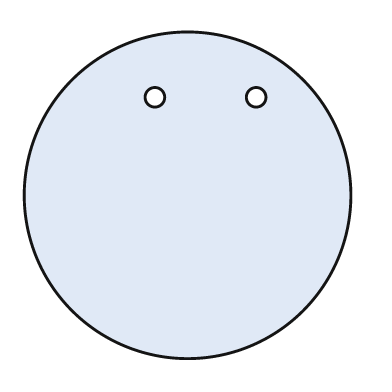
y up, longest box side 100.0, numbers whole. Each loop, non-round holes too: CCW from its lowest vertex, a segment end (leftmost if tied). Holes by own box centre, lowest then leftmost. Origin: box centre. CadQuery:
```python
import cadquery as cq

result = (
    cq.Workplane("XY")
    .moveTo(0.0, 0.0)
    .circle(50.0)
    .moveTo(-10.0, 30.0)
    .circle(3.0)
    .moveTo(21.0, 30.0)
    .circle(3.0)
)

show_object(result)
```